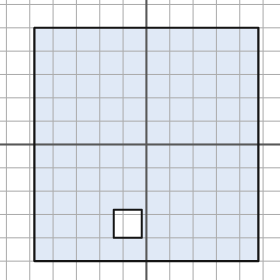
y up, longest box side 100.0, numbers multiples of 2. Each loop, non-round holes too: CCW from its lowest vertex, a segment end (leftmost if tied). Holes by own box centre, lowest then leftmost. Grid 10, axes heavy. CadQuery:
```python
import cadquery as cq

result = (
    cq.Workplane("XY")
    .moveTo(-48.0, -50.0)
    .lineTo(48.0, -50.0)
    .lineTo(48.0, 50.0)
    .lineTo(-48.0, 50.0)
    .close()
    .moveTo(-14.0, -40.0)
    .lineTo(-2.0, -40.0)
    .lineTo(-2.0, -28.0)
    .lineTo(-14.0, -28.0)
    .close()
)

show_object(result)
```